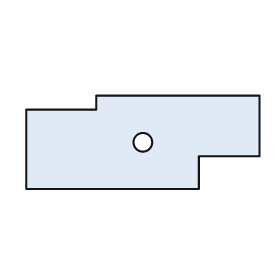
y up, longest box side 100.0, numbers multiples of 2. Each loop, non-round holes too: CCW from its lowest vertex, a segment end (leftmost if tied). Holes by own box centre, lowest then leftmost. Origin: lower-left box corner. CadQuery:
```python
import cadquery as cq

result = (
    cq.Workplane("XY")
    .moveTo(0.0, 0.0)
    .lineTo(74.0, 0.0)
    .lineTo(74.0, 14.0)
    .lineTo(100.0, 14.0)
    .lineTo(100.0, 40.0)
    .lineTo(30.0, 40.0)
    .lineTo(30.0, 34.0)
    .lineTo(0.0, 34.0)
    .close()
    .moveTo(50.0, 20.0)
    .circle(4.0)
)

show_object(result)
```